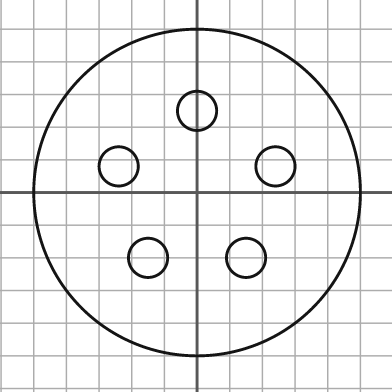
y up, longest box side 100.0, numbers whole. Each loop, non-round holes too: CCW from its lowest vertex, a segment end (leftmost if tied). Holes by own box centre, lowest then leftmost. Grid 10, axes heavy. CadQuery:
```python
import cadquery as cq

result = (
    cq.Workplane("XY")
    .moveTo(0.0, 0.0)
    .circle(50.0)
    .moveTo(-15.0, -20.0)
    .circle(6.0)
    .moveTo(15.0, -20.0)
    .circle(6.0)
    .moveTo(-24.0, 8.0)
    .circle(6.0)
    .moveTo(24.0, 8.0)
    .circle(6.0)
    .moveTo(0.0, 25.0)
    .circle(6.0)
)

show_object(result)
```